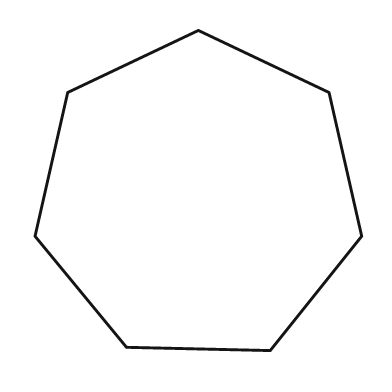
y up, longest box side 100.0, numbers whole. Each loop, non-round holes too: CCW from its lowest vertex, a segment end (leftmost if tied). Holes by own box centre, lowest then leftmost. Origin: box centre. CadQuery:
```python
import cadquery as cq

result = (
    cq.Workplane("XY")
    .moveTo(22.0, -49.0)
    .lineTo(50.0, -14.0)
    .lineTo(40.0, 30.0)
    .lineTo(0.0, 49.0)
    .lineTo(-40.0, 30.0)
    .lineTo(-50.0, -14.0)
    .lineTo(-22.0, -48.0)
    .close()
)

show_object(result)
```